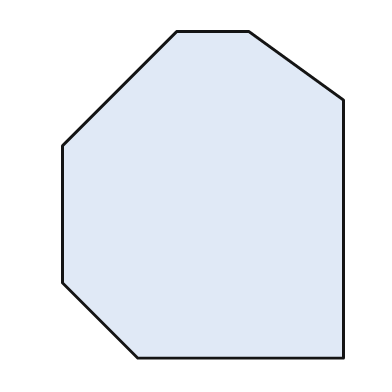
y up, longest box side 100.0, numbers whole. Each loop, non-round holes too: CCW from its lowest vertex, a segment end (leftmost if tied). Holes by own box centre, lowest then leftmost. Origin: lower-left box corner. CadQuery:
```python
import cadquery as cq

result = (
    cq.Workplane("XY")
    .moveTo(23.0, 0.0)
    .lineTo(86.0, 0.0)
    .lineTo(86.0, 79.0)
    .lineTo(57.0, 100.0)
    .lineTo(35.0, 100.0)
    .lineTo(0.0, 65.0)
    .lineTo(0.0, 23.0)
    .close()
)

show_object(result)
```